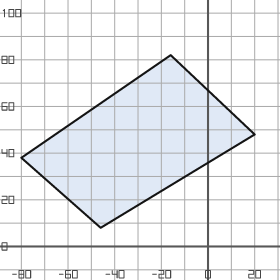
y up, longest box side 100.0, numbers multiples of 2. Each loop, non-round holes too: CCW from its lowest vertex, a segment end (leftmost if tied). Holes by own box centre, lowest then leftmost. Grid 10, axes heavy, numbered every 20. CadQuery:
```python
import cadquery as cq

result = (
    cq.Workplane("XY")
    .moveTo(-46.0, 8.0)
    .lineTo(20.0, 48.0)
    .lineTo(-16.0, 82.0)
    .lineTo(-80.0, 38.0)
    .close()
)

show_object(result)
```